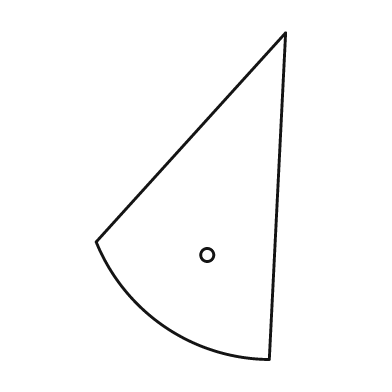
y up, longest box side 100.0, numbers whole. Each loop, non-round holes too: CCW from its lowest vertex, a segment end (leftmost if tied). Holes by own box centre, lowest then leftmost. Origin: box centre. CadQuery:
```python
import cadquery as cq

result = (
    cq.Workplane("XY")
    .moveTo(24.0, -50.0)
    .lineTo(29.0, 50.0)
    .lineTo(-29.0, -14.0)
    .threePointArc((-8.0, -40.0), (24.0, -50.0))
    .close()
    .moveTo(5.0, -18.0)
    .circle(2.0)
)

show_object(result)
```